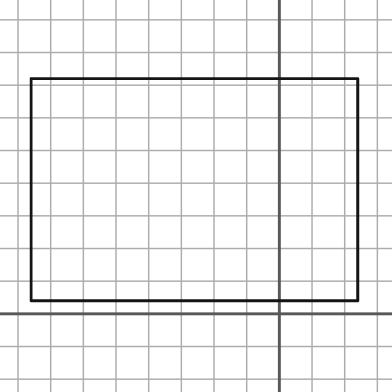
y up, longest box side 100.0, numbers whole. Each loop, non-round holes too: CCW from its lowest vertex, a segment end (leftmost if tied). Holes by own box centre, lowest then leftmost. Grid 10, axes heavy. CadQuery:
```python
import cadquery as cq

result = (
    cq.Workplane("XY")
    .moveTo(-76.0, 4.0)
    .lineTo(24.0, 4.0)
    .lineTo(24.0, 72.0)
    .lineTo(-76.0, 72.0)
    .close()
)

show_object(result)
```